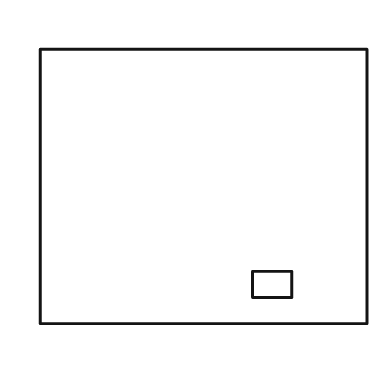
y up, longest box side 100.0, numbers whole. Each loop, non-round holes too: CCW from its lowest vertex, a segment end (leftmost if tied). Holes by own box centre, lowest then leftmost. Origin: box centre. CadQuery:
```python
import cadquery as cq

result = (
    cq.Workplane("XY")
    .moveTo(-50.0, -42.0)
    .lineTo(50.0, -42.0)
    .lineTo(50.0, 42.0)
    .lineTo(-50.0, 42.0)
    .close()
    .moveTo(15.0, -34.0)
    .lineTo(27.0, -34.0)
    .lineTo(27.0, -26.0)
    .lineTo(15.0, -26.0)
    .close()
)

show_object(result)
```